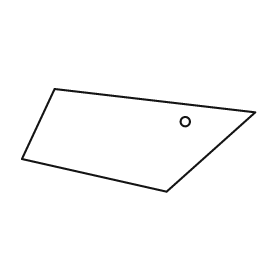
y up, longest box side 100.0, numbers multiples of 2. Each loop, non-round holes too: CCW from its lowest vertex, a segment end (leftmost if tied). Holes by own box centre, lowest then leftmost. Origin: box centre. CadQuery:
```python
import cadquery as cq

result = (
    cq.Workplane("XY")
    .moveTo(12.0, -22.0)
    .lineTo(50.0, 12.0)
    .lineTo(-36.0, 22.0)
    .lineTo(-50.0, -8.0)
    .close()
    .moveTo(20.0, 8.0)
    .circle(2.0)
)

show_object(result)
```